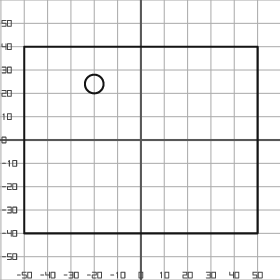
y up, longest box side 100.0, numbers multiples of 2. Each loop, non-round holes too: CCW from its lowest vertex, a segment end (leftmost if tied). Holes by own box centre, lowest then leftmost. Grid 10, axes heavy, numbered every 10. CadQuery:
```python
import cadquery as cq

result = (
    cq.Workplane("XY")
    .moveTo(-50.0, -40.0)
    .lineTo(50.0, -40.0)
    .lineTo(50.0, 40.0)
    .lineTo(-50.0, 40.0)
    .close()
    .moveTo(-20.0, 24.0)
    .circle(4.0)
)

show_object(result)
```